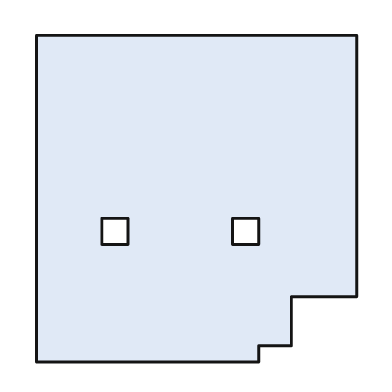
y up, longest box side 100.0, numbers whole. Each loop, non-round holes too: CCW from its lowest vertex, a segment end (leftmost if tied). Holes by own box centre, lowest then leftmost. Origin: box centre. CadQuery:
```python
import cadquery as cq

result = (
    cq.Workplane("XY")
    .moveTo(-49.0, -50.0)
    .lineTo(19.0, -50.0)
    .lineTo(19.0, -45.0)
    .lineTo(29.0, -45.0)
    .lineTo(29.0, -30.0)
    .lineTo(49.0, -30.0)
    .lineTo(49.0, 50.0)
    .lineTo(-49.0, 50.0)
    .close()
    .moveTo(-29.0, -14.0)
    .lineTo(-21.0, -14.0)
    .lineTo(-21.0, -6.0)
    .lineTo(-29.0, -6.0)
    .close()
    .moveTo(11.0, -14.0)
    .lineTo(19.0, -14.0)
    .lineTo(19.0, -6.0)
    .lineTo(11.0, -6.0)
    .close()
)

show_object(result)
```